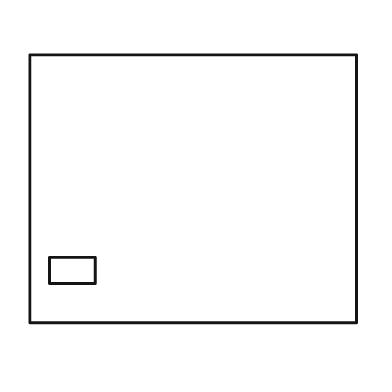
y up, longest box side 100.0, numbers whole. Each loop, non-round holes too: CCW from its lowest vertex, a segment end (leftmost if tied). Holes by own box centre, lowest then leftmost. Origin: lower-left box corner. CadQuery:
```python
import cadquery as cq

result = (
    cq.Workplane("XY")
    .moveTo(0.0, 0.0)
    .lineTo(100.0, 0.0)
    .lineTo(100.0, 82.0)
    .lineTo(0.0, 82.0)
    .close()
    .moveTo(6.0, 12.0)
    .lineTo(20.0, 12.0)
    .lineTo(20.0, 20.0)
    .lineTo(6.0, 20.0)
    .close()
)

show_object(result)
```